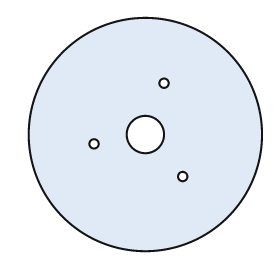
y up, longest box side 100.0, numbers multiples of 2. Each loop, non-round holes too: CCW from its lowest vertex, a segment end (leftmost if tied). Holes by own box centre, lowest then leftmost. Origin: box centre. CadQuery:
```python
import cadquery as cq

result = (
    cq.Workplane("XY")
    .moveTo(0.0, 0.0)
    .circle(50.0)
    .moveTo(16.0, -18.0)
    .circle(2.0)
    .moveTo(-22.0, -4.0)
    .circle(2.0)
    .moveTo(0.0, 0.0)
    .circle(8.0)
    .moveTo(8.0, 22.0)
    .circle(2.0)
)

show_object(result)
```